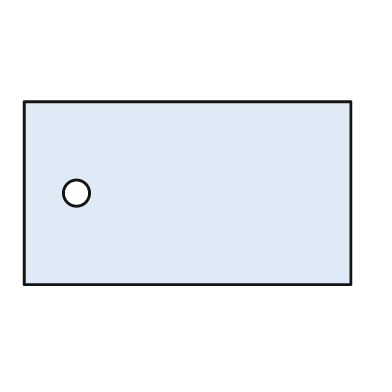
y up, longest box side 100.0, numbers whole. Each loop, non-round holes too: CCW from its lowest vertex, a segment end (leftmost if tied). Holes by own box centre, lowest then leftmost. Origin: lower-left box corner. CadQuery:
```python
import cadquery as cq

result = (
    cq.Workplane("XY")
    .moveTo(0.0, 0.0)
    .lineTo(100.0, 0.0)
    .lineTo(100.0, 56.0)
    .lineTo(0.0, 56.0)
    .close()
    .moveTo(16.0, 28.0)
    .circle(4.0)
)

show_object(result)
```